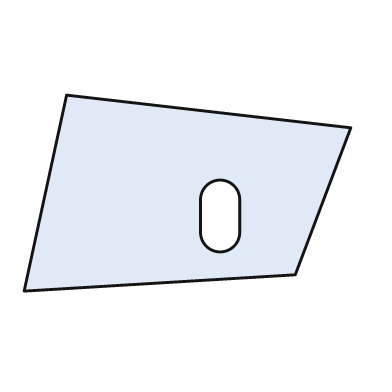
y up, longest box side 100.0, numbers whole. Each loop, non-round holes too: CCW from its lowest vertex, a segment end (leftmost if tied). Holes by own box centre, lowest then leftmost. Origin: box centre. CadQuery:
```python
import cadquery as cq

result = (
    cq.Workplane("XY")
    .moveTo(-50.0, -30.0)
    .lineTo(33.0, -25.0)
    .lineTo(50.0, 20.0)
    .lineTo(-37.0, 30.0)
    .close()
    .moveTo(4.0, -12.0)
    .threePointArc((10.0, -18.0), (16.0, -12.0))
    .lineTo(16.0, -2.0)
    .threePointArc((10.0, 4.0), (4.0, -2.0))
    .close()
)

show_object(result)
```